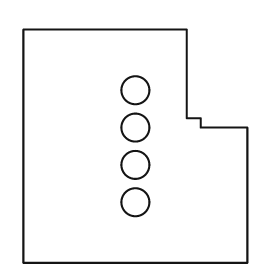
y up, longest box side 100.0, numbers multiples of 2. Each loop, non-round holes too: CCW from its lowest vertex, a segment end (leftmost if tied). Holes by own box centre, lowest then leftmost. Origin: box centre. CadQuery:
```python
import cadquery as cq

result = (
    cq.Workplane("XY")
    .moveTo(-48.0, -50.0)
    .lineTo(48.0, -50.0)
    .lineTo(48.0, 8.0)
    .lineTo(28.0, 8.0)
    .lineTo(28.0, 12.0)
    .lineTo(22.0, 12.0)
    .lineTo(22.0, 50.0)
    .lineTo(-48.0, 50.0)
    .close()
    .moveTo(0.0, -24.0)
    .circle(6.0)
    .moveTo(0.0, -8.0)
    .circle(6.0)
    .moveTo(0.0, 8.0)
    .circle(6.0)
    .moveTo(0.0, 24.0)
    .circle(6.0)
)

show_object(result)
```